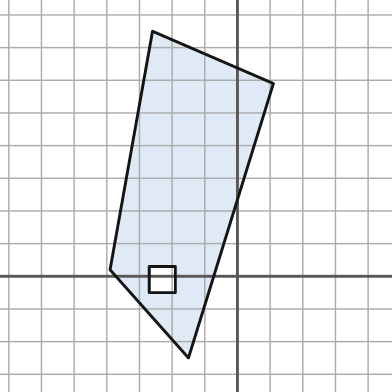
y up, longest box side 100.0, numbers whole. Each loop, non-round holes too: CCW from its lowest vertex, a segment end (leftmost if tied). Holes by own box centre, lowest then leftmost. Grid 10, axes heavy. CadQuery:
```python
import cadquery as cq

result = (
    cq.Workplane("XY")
    .moveTo(-15.0, -25.0)
    .lineTo(11.0, 59.0)
    .lineTo(-26.0, 75.0)
    .lineTo(-39.0, 2.0)
    .close()
    .moveTo(-27.0, -5.0)
    .lineTo(-19.0, -5.0)
    .lineTo(-19.0, 3.0)
    .lineTo(-27.0, 3.0)
    .close()
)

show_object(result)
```